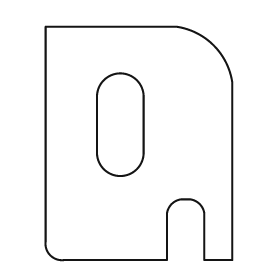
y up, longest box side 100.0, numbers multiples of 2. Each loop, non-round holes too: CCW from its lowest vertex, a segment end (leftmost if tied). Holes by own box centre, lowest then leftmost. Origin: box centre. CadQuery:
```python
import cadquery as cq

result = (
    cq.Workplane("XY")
    .moveTo(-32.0, -50.0)
    .lineTo(12.0, -50.0)
    .lineTo(12.0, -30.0)
    .threePointArc((14.0, -26.0), (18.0, -24.0))
    .lineTo(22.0, -24.0)
    .threePointArc((26.0, -26.0), (28.0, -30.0))
    .lineTo(28.0, -50.0)
    .lineTo(40.0, -50.0)
    .lineTo(40.0, 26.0)
    .threePointArc((32.0, 42.0), (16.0, 50.0))
    .lineTo(-40.0, 50.0)
    .lineTo(-40.0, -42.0)
    .threePointArc((-38.0, -48.0), (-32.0, -50.0))
    .close()
    .moveTo(-18.0, -4.0)
    .threePointArc((-8.0, -14.0), (2.0, -4.0))
    .lineTo(2.0, 20.0)
    .threePointArc((-8.0, 30.0), (-18.0, 20.0))
    .close()
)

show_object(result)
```